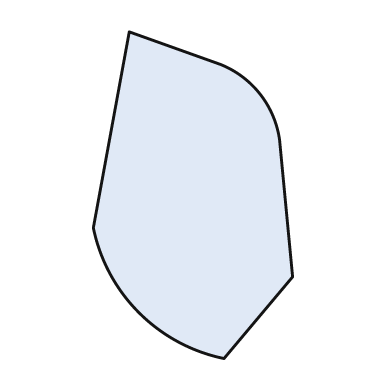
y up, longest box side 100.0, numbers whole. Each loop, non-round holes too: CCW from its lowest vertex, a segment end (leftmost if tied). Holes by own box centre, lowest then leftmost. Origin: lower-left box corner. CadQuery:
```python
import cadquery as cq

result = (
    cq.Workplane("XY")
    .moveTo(40.0, 0.0)
    .lineTo(61.0, 25.0)
    .lineTo(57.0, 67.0)
    .threePointArc((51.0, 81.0), (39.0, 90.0))
    .lineTo(11.0, 100.0)
    .lineTo(0.0, 40.0)
    .threePointArc((14.0, 14.0), (40.0, 0.0))
    .close()
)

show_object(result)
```